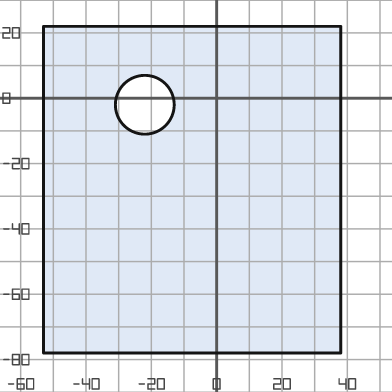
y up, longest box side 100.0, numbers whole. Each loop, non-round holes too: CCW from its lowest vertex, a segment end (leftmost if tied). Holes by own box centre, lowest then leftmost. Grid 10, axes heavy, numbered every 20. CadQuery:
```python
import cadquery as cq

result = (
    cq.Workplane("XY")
    .moveTo(-53.0, -78.0)
    .lineTo(38.0, -78.0)
    .lineTo(38.0, 22.0)
    .lineTo(-53.0, 22.0)
    .close()
    .moveTo(-22.0, -2.0)
    .circle(9.0)
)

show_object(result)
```